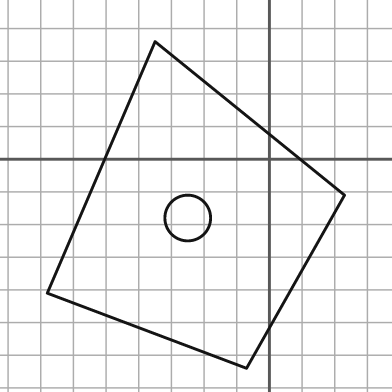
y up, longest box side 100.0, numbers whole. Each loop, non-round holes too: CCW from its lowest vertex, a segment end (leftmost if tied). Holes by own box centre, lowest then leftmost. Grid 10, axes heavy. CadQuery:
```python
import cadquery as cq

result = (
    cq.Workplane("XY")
    .moveTo(-7.0, -64.0)
    .lineTo(23.0, -11.0)
    .lineTo(-35.0, 36.0)
    .lineTo(-68.0, -41.0)
    .close()
    .moveTo(-25.0, -18.0)
    .circle(7.0)
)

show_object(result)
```